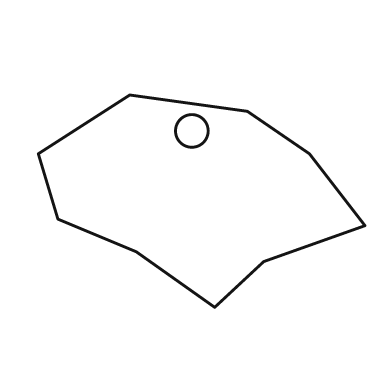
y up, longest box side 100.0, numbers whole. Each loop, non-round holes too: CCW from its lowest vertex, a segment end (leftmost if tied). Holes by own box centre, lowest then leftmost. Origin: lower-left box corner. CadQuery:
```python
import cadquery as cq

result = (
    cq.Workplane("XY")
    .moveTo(54.0, 0.0)
    .lineTo(69.0, 14.0)
    .lineTo(100.0, 25.0)
    .lineTo(83.0, 47.0)
    .lineTo(64.0, 60.0)
    .lineTo(28.0, 65.0)
    .lineTo(0.0, 47.0)
    .lineTo(6.0, 27.0)
    .lineTo(30.0, 17.0)
    .close()
    .moveTo(47.0, 54.0)
    .circle(5.0)
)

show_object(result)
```